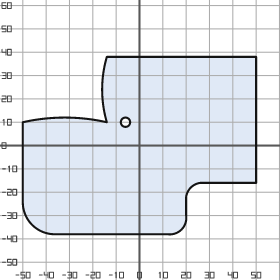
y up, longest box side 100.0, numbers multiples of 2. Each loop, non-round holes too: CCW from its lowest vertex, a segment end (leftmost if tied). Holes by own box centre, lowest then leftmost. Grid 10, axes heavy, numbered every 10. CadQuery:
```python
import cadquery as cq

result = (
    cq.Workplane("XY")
    .moveTo(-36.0, -38.0)
    .lineTo(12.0, -38.0)
    .threePointArc((18.0, -36.0), (20.0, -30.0))
    .lineTo(20.0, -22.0)
    .threePointArc((22.0, -18.0), (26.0, -16.0))
    .lineTo(50.0, -16.0)
    .lineTo(50.0, 38.0)
    .lineTo(-14.0, 38.0)
    .threePointArc((-16.0, 24.0), (-14.0, 10.0))
    .threePointArc((-32.0, 12.0), (-50.0, 10.0))
    .lineTo(-50.0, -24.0)
    .threePointArc((-46.0, -34.0), (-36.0, -38.0))
    .close()
    .moveTo(-6.0, 10.0)
    .circle(2.0)
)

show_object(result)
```